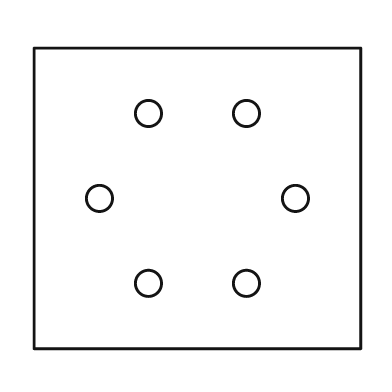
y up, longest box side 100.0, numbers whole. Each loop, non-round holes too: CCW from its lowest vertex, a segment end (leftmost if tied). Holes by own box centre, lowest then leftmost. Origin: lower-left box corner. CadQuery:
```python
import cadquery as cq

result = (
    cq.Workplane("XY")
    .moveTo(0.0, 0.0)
    .lineTo(100.0, 0.0)
    .lineTo(100.0, 92.0)
    .lineTo(0.0, 92.0)
    .close()
    .moveTo(35.0, 20.0)
    .circle(4.0)
    .moveTo(65.0, 20.0)
    .circle(4.0)
    .moveTo(20.0, 46.0)
    .circle(4.0)
    .moveTo(80.0, 46.0)
    .circle(4.0)
    .moveTo(35.0, 72.0)
    .circle(4.0)
    .moveTo(65.0, 72.0)
    .circle(4.0)
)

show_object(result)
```